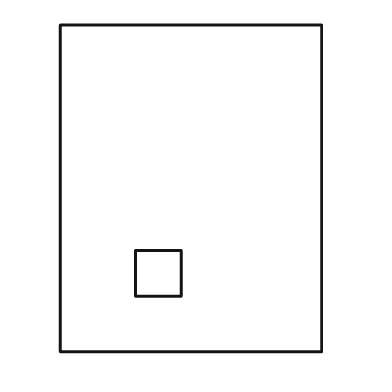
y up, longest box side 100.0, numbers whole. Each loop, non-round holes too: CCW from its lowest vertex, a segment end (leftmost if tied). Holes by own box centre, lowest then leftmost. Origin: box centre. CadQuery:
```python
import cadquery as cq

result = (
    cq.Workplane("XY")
    .moveTo(-40.0, -50.0)
    .lineTo(40.0, -50.0)
    .lineTo(40.0, 50.0)
    .lineTo(-40.0, 50.0)
    .close()
    .moveTo(-17.0, -33.0)
    .lineTo(-3.0, -33.0)
    .lineTo(-3.0, -19.0)
    .lineTo(-17.0, -19.0)
    .close()
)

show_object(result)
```